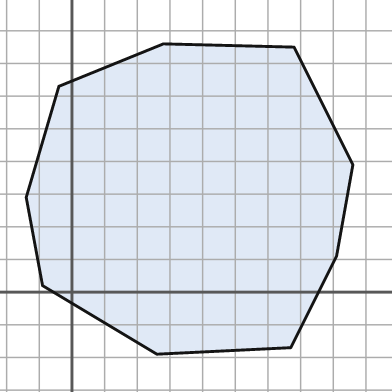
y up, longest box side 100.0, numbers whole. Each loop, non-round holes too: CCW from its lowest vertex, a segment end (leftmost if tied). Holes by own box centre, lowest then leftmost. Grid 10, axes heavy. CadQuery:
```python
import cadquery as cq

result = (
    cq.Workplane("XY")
    .moveTo(26.0, -19.0)
    .lineTo(67.0, -17.0)
    .lineTo(81.0, 11.0)
    .lineTo(86.0, 39.0)
    .lineTo(68.0, 75.0)
    .lineTo(28.0, 76.0)
    .lineTo(-4.0, 63.0)
    .lineTo(-14.0, 29.0)
    .lineTo(-9.0, 2.0)
    .close()
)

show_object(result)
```